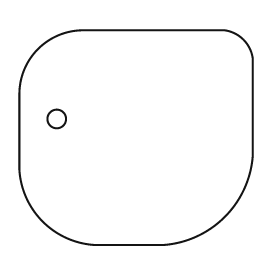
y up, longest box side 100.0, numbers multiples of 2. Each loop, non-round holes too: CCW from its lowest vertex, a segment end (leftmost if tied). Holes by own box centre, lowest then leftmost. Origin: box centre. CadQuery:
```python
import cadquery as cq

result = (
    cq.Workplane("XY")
    .moveTo(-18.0, -46.0)
    .lineTo(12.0, -46.0)
    .threePointArc((38.0, -34.0), (50.0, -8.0))
    .lineTo(50.0, 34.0)
    .threePointArc((46.0, 42.0), (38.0, 46.0))
    .lineTo(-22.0, 46.0)
    .threePointArc((-42.0, 38.0), (-50.0, 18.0))
    .lineTo(-50.0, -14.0)
    .threePointArc((-40.0, -36.0), (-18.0, -46.0))
    .close()
    .moveTo(-34.0, 8.0)
    .circle(4.0)
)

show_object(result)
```